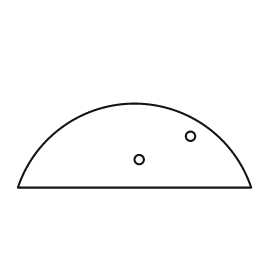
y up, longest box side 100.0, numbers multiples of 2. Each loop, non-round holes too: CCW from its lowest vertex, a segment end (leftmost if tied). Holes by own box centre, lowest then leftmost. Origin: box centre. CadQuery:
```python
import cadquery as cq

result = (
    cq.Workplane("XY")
    .moveTo(-50.0, -18.0)
    .lineTo(50.0, -18.0)
    .threePointArc((0.0, 18.0), (-50.0, -18.0))
    .close()
    .moveTo(2.0, -6.0)
    .circle(2.0)
    .moveTo(24.0, 4.0)
    .circle(2.0)
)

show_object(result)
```